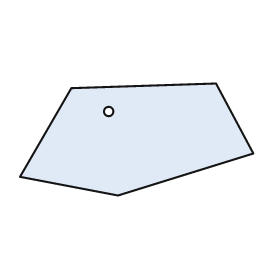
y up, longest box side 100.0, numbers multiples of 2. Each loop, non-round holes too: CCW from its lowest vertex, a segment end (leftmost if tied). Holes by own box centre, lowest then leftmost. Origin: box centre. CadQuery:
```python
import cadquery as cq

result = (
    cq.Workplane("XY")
    .moveTo(-8.0, -24.0)
    .lineTo(50.0, -6.0)
    .lineTo(34.0, 24.0)
    .lineTo(-28.0, 22.0)
    .lineTo(-50.0, -16.0)
    .close()
    .moveTo(-12.0, 12.0)
    .circle(2.0)
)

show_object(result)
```